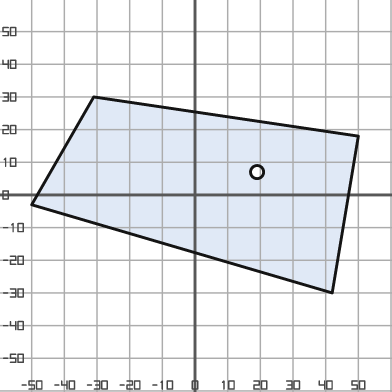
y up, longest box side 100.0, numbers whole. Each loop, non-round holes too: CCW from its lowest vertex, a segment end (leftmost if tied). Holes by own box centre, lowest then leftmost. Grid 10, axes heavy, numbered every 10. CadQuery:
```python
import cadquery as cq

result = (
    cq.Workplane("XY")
    .moveTo(42.0, -30.0)
    .lineTo(50.0, 18.0)
    .lineTo(-31.0, 30.0)
    .lineTo(-50.0, -3.0)
    .close()
    .moveTo(19.0, 7.0)
    .circle(2.0)
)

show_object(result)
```